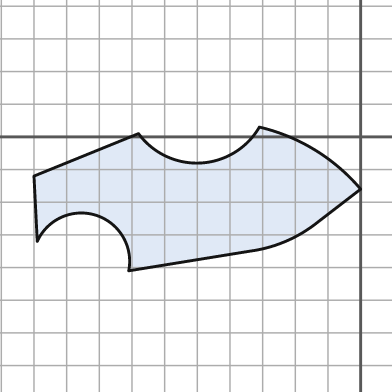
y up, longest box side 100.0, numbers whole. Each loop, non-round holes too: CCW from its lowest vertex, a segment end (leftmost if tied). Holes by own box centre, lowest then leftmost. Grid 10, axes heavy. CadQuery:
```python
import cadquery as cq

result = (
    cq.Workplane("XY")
    .moveTo(-71.0, -41.0)
    .lineTo(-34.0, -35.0)
    .threePointArc((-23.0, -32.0), (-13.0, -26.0))
    .lineTo(0.0, -16.0)
    .threePointArc((-14.0, -4.0), (-31.0, 3.0))
    .threePointArc((-49.0, -8.0), (-68.0, 1.0))
    .lineTo(-100.0, -12.0)
    .lineTo(-99.0, -32.0)
    .threePointArc((-81.0, -24.0), (-71.0, -41.0))
    .close()
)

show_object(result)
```